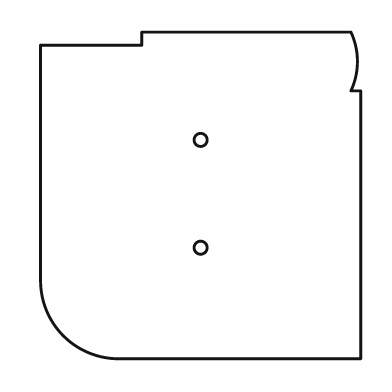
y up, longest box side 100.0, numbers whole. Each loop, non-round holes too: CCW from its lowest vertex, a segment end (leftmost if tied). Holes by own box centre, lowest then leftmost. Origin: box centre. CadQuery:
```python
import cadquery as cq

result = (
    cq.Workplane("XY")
    .moveTo(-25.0, -50.0)
    .lineTo(49.0, -50.0)
    .lineTo(49.0, 32.0)
    .lineTo(46.0, 32.0)
    .threePointArc((48.0, 41.0), (46.0, 50.0))
    .lineTo(-18.0, 50.0)
    .lineTo(-18.0, 46.0)
    .lineTo(-49.0, 46.0)
    .lineTo(-49.0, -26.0)
    .threePointArc((-42.0, -43.0), (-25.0, -50.0))
    .close()
    .moveTo(0.0, -16.0)
    .circle(2.0)
    .moveTo(0.0, 17.0)
    .circle(2.0)
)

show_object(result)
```